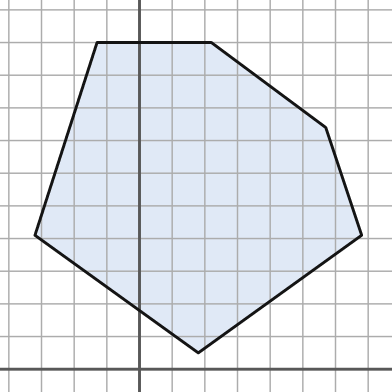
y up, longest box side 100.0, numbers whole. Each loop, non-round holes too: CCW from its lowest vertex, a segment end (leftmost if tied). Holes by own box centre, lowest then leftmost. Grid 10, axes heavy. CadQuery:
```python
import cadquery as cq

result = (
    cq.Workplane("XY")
    .moveTo(18.0, 5.0)
    .lineTo(68.0, 41.0)
    .lineTo(57.0, 74.0)
    .lineTo(22.0, 100.0)
    .lineTo(-13.0, 100.0)
    .lineTo(-32.0, 41.0)
    .close()
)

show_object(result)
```